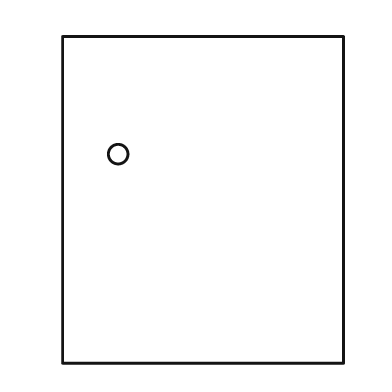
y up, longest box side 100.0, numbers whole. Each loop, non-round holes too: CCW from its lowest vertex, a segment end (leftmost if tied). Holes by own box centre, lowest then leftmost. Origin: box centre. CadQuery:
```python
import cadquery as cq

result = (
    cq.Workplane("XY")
    .moveTo(-43.0, -50.0)
    .lineTo(43.0, -50.0)
    .lineTo(43.0, 50.0)
    .lineTo(-43.0, 50.0)
    .close()
    .moveTo(-26.0, 14.0)
    .circle(3.0)
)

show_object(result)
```